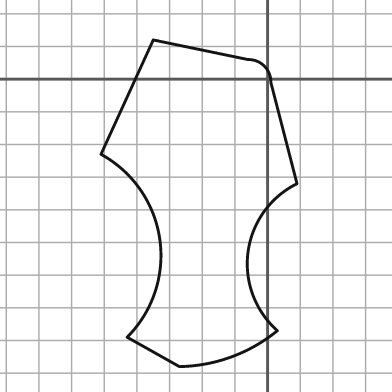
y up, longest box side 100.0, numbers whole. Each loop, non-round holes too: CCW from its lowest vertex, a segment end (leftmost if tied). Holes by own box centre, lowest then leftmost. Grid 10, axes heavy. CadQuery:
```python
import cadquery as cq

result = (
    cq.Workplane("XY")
    .moveTo(-27.0, -88.0)
    .threePointArc((-11.0, -85.0), (3.0, -77.0))
    .threePointArc((-6.0, -53.0), (9.0, -32.0))
    .lineTo(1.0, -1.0)
    .threePointArc((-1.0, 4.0), (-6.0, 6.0))
    .lineTo(-35.0, 12.0)
    .lineTo(-51.0, -23.0)
    .threePointArc((-33.0, -49.0), (-43.0, -79.0))
    .close()
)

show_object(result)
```